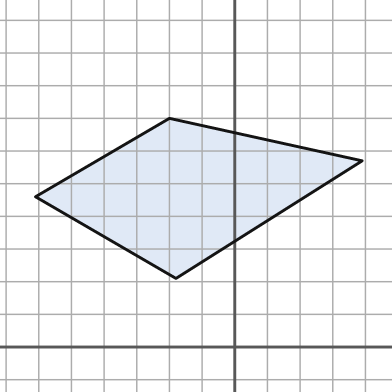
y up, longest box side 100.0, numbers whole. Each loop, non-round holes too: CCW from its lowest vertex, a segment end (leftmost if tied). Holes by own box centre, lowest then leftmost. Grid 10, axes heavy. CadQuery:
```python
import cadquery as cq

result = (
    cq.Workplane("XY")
    .moveTo(-18.0, 21.0)
    .lineTo(39.0, 57.0)
    .lineTo(-20.0, 70.0)
    .lineTo(-61.0, 46.0)
    .close()
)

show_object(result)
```